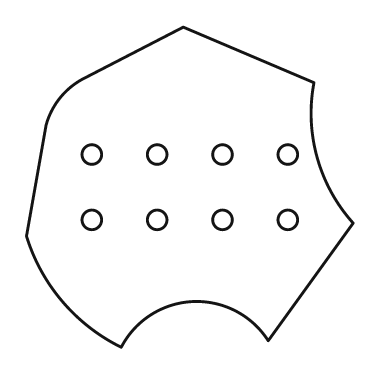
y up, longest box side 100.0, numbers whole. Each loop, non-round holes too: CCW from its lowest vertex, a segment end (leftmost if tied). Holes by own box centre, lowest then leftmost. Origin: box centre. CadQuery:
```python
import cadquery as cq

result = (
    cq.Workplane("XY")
    .moveTo(-21.0, -49.0)
    .threePointArc((1.0, -35.0), (24.0, -47.0))
    .lineTo(50.0, -11.0)
    .threePointArc((39.0, 9.0), (38.0, 32.0))
    .lineTo(-2.0, 49.0)
    .lineTo(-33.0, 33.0)
    .threePointArc((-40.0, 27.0), (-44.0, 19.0))
    .lineTo(-50.0, -15.0)
    .threePointArc((-39.0, -35.0), (-21.0, -49.0))
    .close()
    .moveTo(-30.0, -10.0)
    .circle(3.0)
    .moveTo(-10.0, -10.0)
    .circle(3.0)
    .moveTo(10.0, -10.0)
    .circle(3.0)
    .moveTo(30.0, -10.0)
    .circle(3.0)
    .moveTo(-30.0, 10.0)
    .circle(3.0)
    .moveTo(-10.0, 10.0)
    .circle(3.0)
    .moveTo(10.0, 10.0)
    .circle(3.0)
    .moveTo(30.0, 10.0)
    .circle(3.0)
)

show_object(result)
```